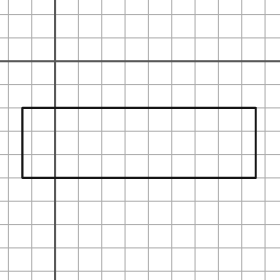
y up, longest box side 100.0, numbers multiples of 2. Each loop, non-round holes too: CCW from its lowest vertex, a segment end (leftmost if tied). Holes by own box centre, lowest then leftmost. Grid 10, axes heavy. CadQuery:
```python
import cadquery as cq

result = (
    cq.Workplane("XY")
    .moveTo(-14.0, -50.0)
    .lineTo(86.0, -50.0)
    .lineTo(86.0, -20.0)
    .lineTo(-14.0, -20.0)
    .close()
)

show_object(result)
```